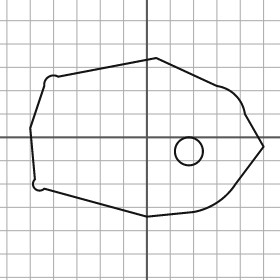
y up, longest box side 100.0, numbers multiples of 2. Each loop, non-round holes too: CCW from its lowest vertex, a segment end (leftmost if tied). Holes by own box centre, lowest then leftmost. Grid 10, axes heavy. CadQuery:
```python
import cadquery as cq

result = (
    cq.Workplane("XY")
    .moveTo(0.0, -34.0)
    .lineTo(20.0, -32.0)
    .threePointArc((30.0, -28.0), (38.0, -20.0))
    .lineTo(50.0, -4.0)
    .lineTo(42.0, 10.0)
    .threePointArc((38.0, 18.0), (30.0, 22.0))
    .lineTo(4.0, 34.0)
    .lineTo(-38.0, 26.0)
    .threePointArc((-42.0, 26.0), (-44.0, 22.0))
    .lineTo(-50.0, 4.0)
    .lineTo(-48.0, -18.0)
    .threePointArc((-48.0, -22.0), (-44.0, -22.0))
    .close()
    .moveTo(18.0, -6.0)
    .circle(6.0)
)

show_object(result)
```